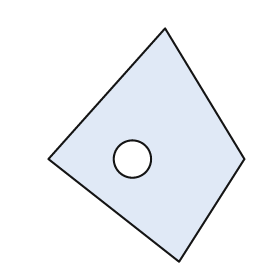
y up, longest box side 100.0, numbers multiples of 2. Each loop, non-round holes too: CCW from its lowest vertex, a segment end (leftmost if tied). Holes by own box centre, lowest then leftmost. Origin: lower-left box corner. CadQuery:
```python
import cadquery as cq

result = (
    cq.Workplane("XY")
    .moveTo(56.0, 0.0)
    .lineTo(84.0, 44.0)
    .lineTo(50.0, 100.0)
    .lineTo(0.0, 44.0)
    .close()
    .moveTo(36.0, 44.0)
    .circle(8.0)
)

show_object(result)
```